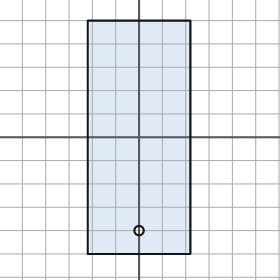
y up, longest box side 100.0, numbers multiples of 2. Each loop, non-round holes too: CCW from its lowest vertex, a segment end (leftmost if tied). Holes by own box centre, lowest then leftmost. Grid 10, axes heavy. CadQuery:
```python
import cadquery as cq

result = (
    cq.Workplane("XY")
    .moveTo(-22.0, -50.0)
    .lineTo(22.0, -50.0)
    .lineTo(22.0, 50.0)
    .lineTo(-22.0, 50.0)
    .close()
    .moveTo(0.0, -40.0)
    .circle(2.0)
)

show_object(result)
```